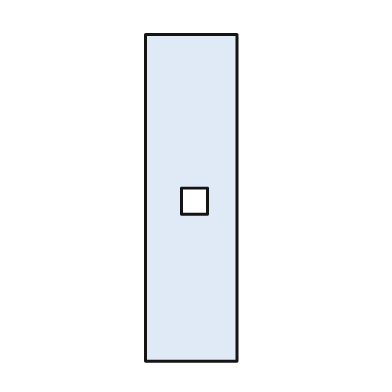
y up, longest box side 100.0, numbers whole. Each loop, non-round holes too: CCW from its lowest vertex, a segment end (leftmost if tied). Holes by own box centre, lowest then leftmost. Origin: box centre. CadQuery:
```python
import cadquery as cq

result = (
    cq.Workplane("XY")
    .moveTo(-14.0, -50.0)
    .lineTo(14.0, -50.0)
    .lineTo(14.0, 50.0)
    .lineTo(-14.0, 50.0)
    .close()
    .moveTo(-3.0, -5.0)
    .lineTo(5.0, -5.0)
    .lineTo(5.0, 3.0)
    .lineTo(-3.0, 3.0)
    .close()
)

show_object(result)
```